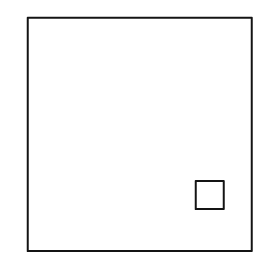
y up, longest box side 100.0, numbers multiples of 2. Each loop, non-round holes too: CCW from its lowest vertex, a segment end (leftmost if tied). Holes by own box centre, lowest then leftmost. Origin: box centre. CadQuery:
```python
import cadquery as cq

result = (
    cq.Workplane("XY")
    .moveTo(-48.0, -50.0)
    .lineTo(48.0, -50.0)
    .lineTo(48.0, 50.0)
    .lineTo(-48.0, 50.0)
    .close()
    .moveTo(24.0, -32.0)
    .lineTo(36.0, -32.0)
    .lineTo(36.0, -20.0)
    .lineTo(24.0, -20.0)
    .close()
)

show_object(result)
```